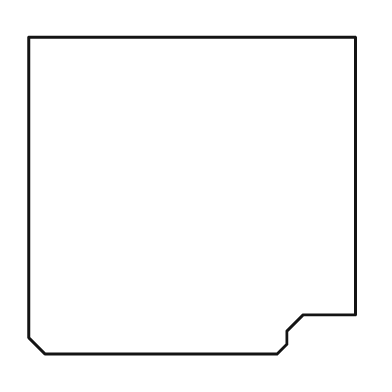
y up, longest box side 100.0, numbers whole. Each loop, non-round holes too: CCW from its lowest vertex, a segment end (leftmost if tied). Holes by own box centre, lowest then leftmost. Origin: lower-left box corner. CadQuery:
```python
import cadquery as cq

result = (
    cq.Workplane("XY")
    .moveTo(5.0, 0.0)
    .lineTo(76.0, 0.0)
    .lineTo(79.0, 3.0)
    .lineTo(79.0, 7.0)
    .lineTo(84.0, 12.0)
    .lineTo(100.0, 12.0)
    .lineTo(100.0, 97.0)
    .lineTo(0.0, 97.0)
    .lineTo(0.0, 5.0)
    .close()
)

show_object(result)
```